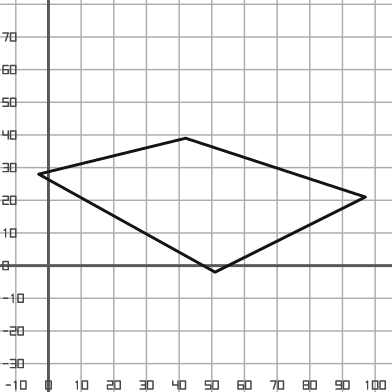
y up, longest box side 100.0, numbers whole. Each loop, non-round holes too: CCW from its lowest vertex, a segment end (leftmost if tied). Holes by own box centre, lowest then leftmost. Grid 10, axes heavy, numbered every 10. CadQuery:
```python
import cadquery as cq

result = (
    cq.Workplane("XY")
    .moveTo(51.0, -2.0)
    .lineTo(97.0, 21.0)
    .lineTo(42.0, 39.0)
    .lineTo(-3.0, 28.0)
    .close()
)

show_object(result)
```